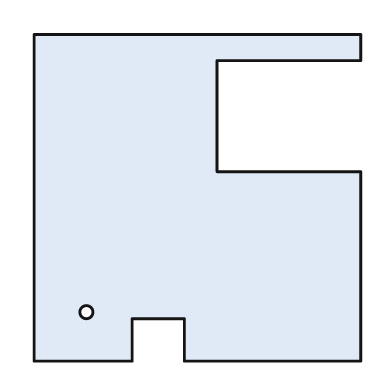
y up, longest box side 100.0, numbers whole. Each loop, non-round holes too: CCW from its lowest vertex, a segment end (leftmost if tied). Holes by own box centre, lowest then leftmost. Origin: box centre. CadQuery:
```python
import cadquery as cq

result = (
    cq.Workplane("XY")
    .moveTo(-50.0, -50.0)
    .lineTo(-20.0, -50.0)
    .lineTo(-20.0, -37.0)
    .lineTo(-4.0, -37.0)
    .lineTo(-4.0, -50.0)
    .lineTo(50.0, -50.0)
    .lineTo(50.0, 8.0)
    .lineTo(6.0, 8.0)
    .lineTo(6.0, 42.0)
    .lineTo(50.0, 42.0)
    .lineTo(50.0, 50.0)
    .lineTo(-50.0, 50.0)
    .close()
    .moveTo(-34.0, -35.0)
    .circle(2.0)
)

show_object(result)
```